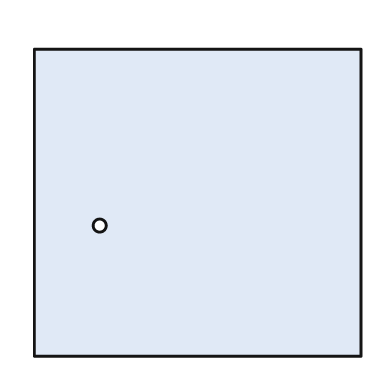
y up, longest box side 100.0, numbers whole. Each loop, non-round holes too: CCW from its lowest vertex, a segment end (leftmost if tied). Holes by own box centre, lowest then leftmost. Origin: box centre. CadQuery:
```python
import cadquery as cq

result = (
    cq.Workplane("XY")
    .moveTo(-50.0, -47.0)
    .lineTo(50.0, -47.0)
    .lineTo(50.0, 47.0)
    .lineTo(-50.0, 47.0)
    .close()
    .moveTo(-30.0, -7.0)
    .circle(2.0)
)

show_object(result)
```